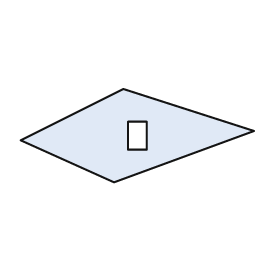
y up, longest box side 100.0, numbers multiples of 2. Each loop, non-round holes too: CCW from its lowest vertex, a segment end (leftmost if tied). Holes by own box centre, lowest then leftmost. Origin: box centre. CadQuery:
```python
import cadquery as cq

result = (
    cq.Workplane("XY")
    .moveTo(-10.0, -20.0)
    .lineTo(50.0, 2.0)
    .lineTo(-6.0, 20.0)
    .lineTo(-50.0, -2.0)
    .close()
    .moveTo(-4.0, -6.0)
    .lineTo(4.0, -6.0)
    .lineTo(4.0, 6.0)
    .lineTo(-4.0, 6.0)
    .close()
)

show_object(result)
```